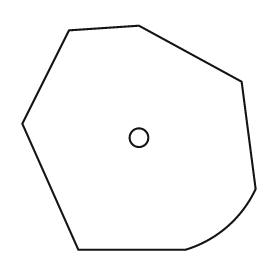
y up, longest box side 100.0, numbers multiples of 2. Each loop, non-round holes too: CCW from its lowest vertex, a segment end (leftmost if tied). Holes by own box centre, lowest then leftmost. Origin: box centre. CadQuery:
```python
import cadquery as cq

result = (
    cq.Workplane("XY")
    .moveTo(-26.0, -48.0)
    .lineTo(20.0, -48.0)
    .threePointArc((38.0, -38.0), (50.0, -22.0))
    .lineTo(44.0, 24.0)
    .lineTo(0.0, 48.0)
    .lineTo(-30.0, 46.0)
    .lineTo(-50.0, 6.0)
    .close()
    .moveTo(0.0, 0.0)
    .circle(4.0)
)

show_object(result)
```